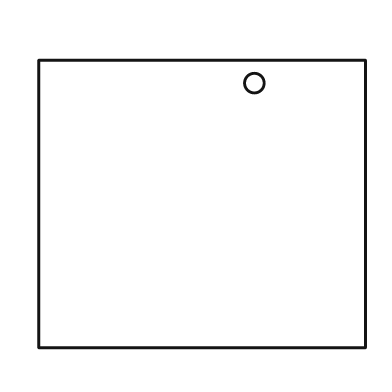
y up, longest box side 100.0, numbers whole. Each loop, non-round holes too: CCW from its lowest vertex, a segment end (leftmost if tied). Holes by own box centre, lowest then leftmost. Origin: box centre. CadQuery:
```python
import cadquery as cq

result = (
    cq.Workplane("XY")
    .moveTo(-50.0, -44.0)
    .lineTo(50.0, -44.0)
    .lineTo(50.0, 44.0)
    .lineTo(-50.0, 44.0)
    .close()
    .moveTo(16.0, 37.0)
    .circle(3.0)
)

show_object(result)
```